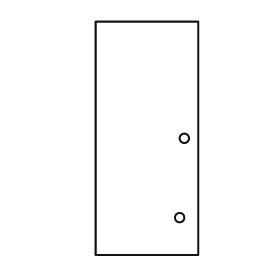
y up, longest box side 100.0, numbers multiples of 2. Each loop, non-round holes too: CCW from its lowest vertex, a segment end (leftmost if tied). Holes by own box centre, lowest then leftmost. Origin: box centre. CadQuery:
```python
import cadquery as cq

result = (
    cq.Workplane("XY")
    .moveTo(-22.0, -50.0)
    .lineTo(22.0, -50.0)
    .lineTo(22.0, 50.0)
    .lineTo(-22.0, 50.0)
    .close()
    .moveTo(14.0, -34.0)
    .circle(2.0)
    .moveTo(16.0, 0.0)
    .circle(2.0)
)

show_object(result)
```